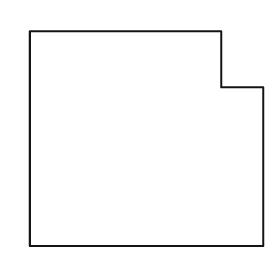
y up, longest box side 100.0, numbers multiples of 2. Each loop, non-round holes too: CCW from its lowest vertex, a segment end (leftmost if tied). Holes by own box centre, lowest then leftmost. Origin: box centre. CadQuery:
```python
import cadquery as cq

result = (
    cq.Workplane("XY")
    .moveTo(-50.0, -46.0)
    .lineTo(50.0, -46.0)
    .lineTo(50.0, 22.0)
    .lineTo(32.0, 22.0)
    .lineTo(32.0, 46.0)
    .lineTo(-50.0, 46.0)
    .close()
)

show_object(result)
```